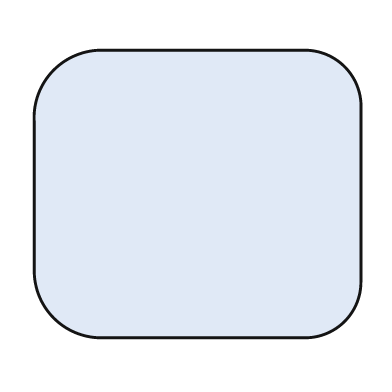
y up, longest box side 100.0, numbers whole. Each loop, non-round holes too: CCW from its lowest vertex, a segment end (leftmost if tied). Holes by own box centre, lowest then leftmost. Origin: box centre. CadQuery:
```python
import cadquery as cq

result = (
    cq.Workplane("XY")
    .moveTo(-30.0, -44.0)
    .lineTo(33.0, -44.0)
    .threePointArc((45.0, -39.0), (50.0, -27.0))
    .lineTo(50.0, 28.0)
    .threePointArc((45.0, 39.0), (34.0, 44.0))
    .lineTo(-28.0, 44.0)
    .threePointArc((-44.0, 38.0), (-50.0, 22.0))
    .lineTo(-50.0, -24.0)
    .threePointArc((-44.0, -38.0), (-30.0, -44.0))
    .close()
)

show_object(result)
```